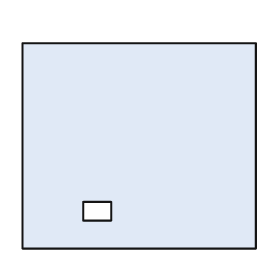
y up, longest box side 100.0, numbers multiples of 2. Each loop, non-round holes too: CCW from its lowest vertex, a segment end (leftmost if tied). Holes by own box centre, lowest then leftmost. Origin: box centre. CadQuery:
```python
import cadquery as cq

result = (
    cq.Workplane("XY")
    .moveTo(-50.0, -44.0)
    .lineTo(50.0, -44.0)
    .lineTo(50.0, 44.0)
    .lineTo(-50.0, 44.0)
    .close()
    .moveTo(-24.0, -32.0)
    .lineTo(-12.0, -32.0)
    .lineTo(-12.0, -24.0)
    .lineTo(-24.0, -24.0)
    .close()
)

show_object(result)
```